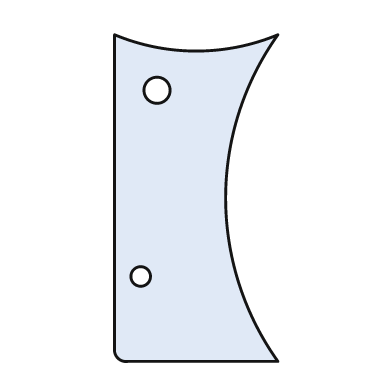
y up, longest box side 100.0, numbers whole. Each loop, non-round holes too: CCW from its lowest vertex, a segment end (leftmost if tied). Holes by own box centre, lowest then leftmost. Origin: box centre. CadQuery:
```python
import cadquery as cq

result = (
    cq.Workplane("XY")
    .moveTo(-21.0, -50.0)
    .lineTo(25.0, -50.0)
    .threePointArc((9.0, 0.0), (25.0, 50.0))
    .threePointArc((0.0, 45.0), (-25.0, 50.0))
    .lineTo(-25.0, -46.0)
    .threePointArc((-24.0, -49.0), (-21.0, -50.0))
    .close()
    .moveTo(-17.0, -24.0)
    .circle(3.0)
    .moveTo(-12.0, 33.0)
    .circle(4.0)
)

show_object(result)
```